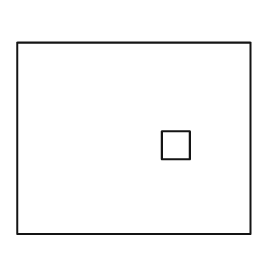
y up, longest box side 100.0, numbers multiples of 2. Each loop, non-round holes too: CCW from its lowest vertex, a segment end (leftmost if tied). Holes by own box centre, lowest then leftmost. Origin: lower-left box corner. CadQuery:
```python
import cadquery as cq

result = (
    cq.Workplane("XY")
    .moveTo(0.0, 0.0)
    .lineTo(100.0, 0.0)
    .lineTo(100.0, 82.0)
    .lineTo(0.0, 82.0)
    .close()
    .moveTo(62.0, 32.0)
    .lineTo(74.0, 32.0)
    .lineTo(74.0, 44.0)
    .lineTo(62.0, 44.0)
    .close()
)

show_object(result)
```